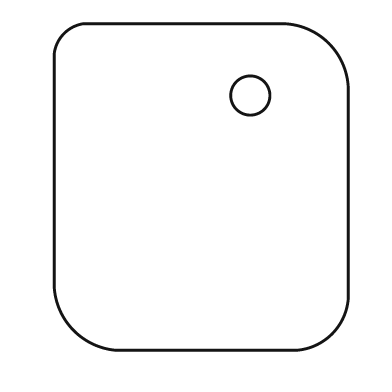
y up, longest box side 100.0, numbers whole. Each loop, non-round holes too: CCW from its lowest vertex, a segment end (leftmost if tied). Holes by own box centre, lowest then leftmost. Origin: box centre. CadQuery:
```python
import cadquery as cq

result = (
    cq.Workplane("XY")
    .moveTo(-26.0, -50.0)
    .lineTo(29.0, -50.0)
    .threePointArc((40.0, -45.0), (45.0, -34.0))
    .lineTo(45.0, 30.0)
    .threePointArc((39.0, 44.0), (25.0, 50.0))
    .lineTo(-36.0, 50.0)
    .threePointArc((-42.0, 47.0), (-45.0, 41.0))
    .lineTo(-45.0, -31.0)
    .threePointArc((-39.0, -44.0), (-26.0, -50.0))
    .close()
    .moveTo(15.0, 28.0)
    .circle(6.0)
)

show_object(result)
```